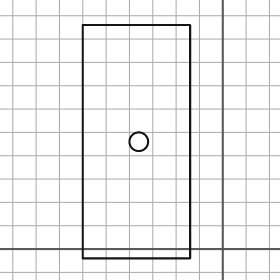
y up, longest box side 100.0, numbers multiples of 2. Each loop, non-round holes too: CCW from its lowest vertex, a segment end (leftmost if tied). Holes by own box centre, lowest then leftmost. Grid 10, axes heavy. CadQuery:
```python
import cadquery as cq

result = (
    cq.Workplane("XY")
    .moveTo(-60.0, -4.0)
    .lineTo(-14.0, -4.0)
    .lineTo(-14.0, 96.0)
    .lineTo(-60.0, 96.0)
    .close()
    .moveTo(-36.0, 46.0)
    .circle(4.0)
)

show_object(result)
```